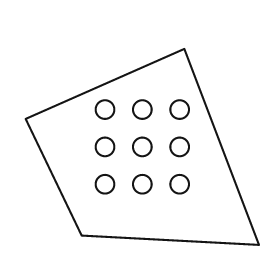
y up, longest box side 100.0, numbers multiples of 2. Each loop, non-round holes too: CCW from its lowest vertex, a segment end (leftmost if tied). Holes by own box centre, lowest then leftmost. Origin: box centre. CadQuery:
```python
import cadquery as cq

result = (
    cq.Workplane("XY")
    .moveTo(50.0, -42.0)
    .lineTo(18.0, 42.0)
    .lineTo(-50.0, 12.0)
    .lineTo(-26.0, -38.0)
    .close()
    .moveTo(-16.0, -16.0)
    .circle(4.0)
    .moveTo(0.0, -16.0)
    .circle(4.0)
    .moveTo(16.0, -16.0)
    .circle(4.0)
    .moveTo(-16.0, 0.0)
    .circle(4.0)
    .moveTo(0.0, 0.0)
    .circle(4.0)
    .moveTo(16.0, 0.0)
    .circle(4.0)
    .moveTo(-16.0, 16.0)
    .circle(4.0)
    .moveTo(0.0, 16.0)
    .circle(4.0)
    .moveTo(16.0, 16.0)
    .circle(4.0)
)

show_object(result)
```